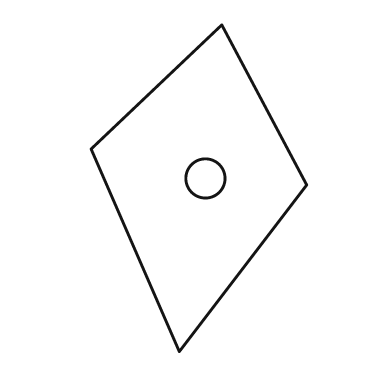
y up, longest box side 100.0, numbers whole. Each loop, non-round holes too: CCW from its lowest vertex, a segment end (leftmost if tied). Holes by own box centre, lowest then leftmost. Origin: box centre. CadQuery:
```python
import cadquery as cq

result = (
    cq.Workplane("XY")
    .moveTo(-6.0, -50.0)
    .lineTo(33.0, 1.0)
    .lineTo(7.0, 50.0)
    .lineTo(-33.0, 12.0)
    .close()
    .moveTo(2.0, 3.0)
    .circle(6.0)
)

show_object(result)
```